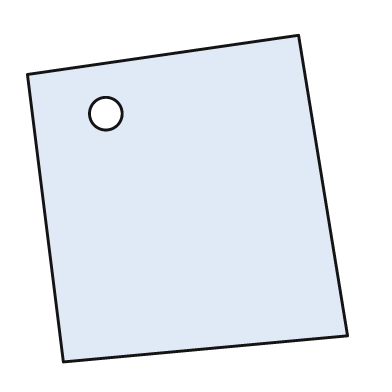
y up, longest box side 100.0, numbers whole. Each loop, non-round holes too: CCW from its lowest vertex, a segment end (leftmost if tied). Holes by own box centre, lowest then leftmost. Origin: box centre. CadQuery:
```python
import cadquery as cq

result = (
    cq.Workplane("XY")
    .moveTo(-38.0, -50.0)
    .lineTo(49.0, -42.0)
    .lineTo(34.0, 50.0)
    .lineTo(-49.0, 38.0)
    .close()
    .moveTo(-25.0, 26.0)
    .circle(5.0)
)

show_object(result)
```